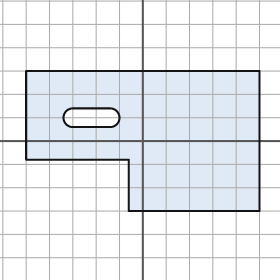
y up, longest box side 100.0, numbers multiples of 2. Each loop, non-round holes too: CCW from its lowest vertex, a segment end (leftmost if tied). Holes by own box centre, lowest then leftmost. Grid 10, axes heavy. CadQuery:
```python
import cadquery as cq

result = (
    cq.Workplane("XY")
    .moveTo(-6.0, -30.0)
    .lineTo(50.0, -30.0)
    .lineTo(50.0, 30.0)
    .lineTo(-50.0, 30.0)
    .lineTo(-50.0, -8.0)
    .lineTo(-6.0, -8.0)
    .close()
    .moveTo(-30.0, 6.0)
    .lineTo(-14.0, 6.0)
    .threePointArc((-10.0, 10.0), (-14.0, 14.0))
    .lineTo(-30.0, 14.0)
    .threePointArc((-34.0, 10.0), (-30.0, 6.0))
    .close()
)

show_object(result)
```